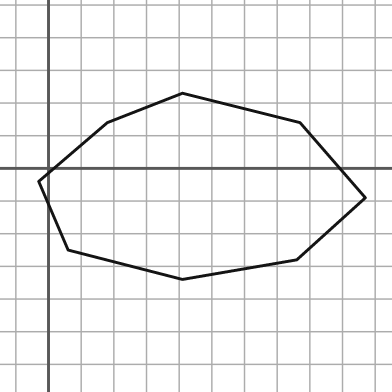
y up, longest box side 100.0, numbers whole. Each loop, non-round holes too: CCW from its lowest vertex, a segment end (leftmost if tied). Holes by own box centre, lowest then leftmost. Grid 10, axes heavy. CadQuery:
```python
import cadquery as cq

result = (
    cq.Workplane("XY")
    .moveTo(41.0, -34.0)
    .lineTo(76.0, -28.0)
    .lineTo(97.0, -9.0)
    .lineTo(77.0, 14.0)
    .lineTo(41.0, 23.0)
    .lineTo(18.0, 14.0)
    .lineTo(-3.0, -4.0)
    .lineTo(6.0, -25.0)
    .close()
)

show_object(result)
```